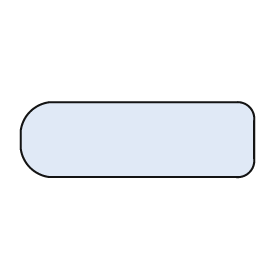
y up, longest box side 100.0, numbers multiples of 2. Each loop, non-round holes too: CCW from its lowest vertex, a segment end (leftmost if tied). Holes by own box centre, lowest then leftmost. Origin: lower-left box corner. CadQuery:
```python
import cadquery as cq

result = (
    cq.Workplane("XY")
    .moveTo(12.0, 0.0)
    .lineTo(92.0, 0.0)
    .threePointArc((98.0, 2.0), (100.0, 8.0))
    .lineTo(100.0, 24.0)
    .threePointArc((98.0, 30.0), (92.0, 32.0))
    .lineTo(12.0, 32.0)
    .threePointArc((4.0, 28.0), (0.0, 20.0))
    .lineTo(0.0, 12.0)
    .threePointArc((4.0, 4.0), (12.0, 0.0))
    .close()
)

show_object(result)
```